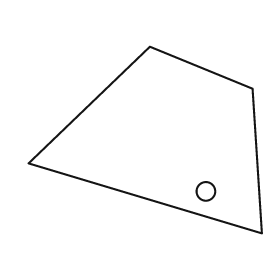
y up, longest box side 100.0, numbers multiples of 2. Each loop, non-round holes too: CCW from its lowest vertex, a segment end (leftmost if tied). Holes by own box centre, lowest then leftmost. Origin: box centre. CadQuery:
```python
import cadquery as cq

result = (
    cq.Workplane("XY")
    .moveTo(50.0, -40.0)
    .lineTo(46.0, 22.0)
    .lineTo(2.0, 40.0)
    .lineTo(-50.0, -10.0)
    .close()
    .moveTo(26.0, -22.0)
    .circle(4.0)
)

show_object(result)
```